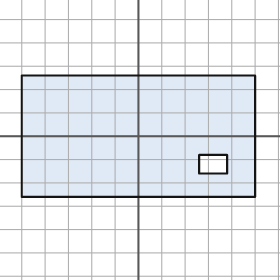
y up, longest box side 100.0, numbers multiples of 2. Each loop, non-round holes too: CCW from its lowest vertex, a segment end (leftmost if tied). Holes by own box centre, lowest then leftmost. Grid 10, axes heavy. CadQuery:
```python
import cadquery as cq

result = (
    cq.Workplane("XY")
    .moveTo(-50.0, -26.0)
    .lineTo(50.0, -26.0)
    .lineTo(50.0, 26.0)
    .lineTo(-50.0, 26.0)
    .close()
    .moveTo(26.0, -16.0)
    .lineTo(38.0, -16.0)
    .lineTo(38.0, -8.0)
    .lineTo(26.0, -8.0)
    .close()
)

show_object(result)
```